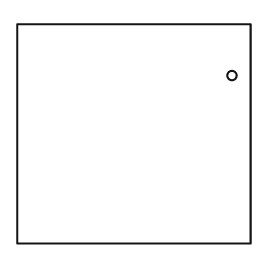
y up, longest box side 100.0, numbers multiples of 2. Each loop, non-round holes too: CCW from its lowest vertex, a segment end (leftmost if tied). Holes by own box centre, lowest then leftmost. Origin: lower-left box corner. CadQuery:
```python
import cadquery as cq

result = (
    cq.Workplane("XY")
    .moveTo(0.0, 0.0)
    .lineTo(100.0, 0.0)
    .lineTo(100.0, 94.0)
    .lineTo(0.0, 94.0)
    .close()
    .moveTo(92.0, 72.0)
    .circle(2.0)
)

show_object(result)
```